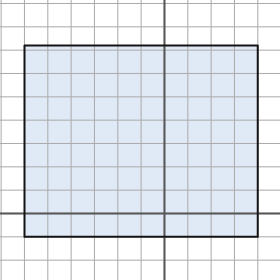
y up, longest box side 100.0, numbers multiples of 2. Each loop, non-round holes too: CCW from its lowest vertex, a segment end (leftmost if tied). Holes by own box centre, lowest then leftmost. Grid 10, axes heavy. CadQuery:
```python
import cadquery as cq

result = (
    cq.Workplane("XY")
    .moveTo(-60.0, -10.0)
    .lineTo(40.0, -10.0)
    .lineTo(40.0, 72.0)
    .lineTo(-60.0, 72.0)
    .close()
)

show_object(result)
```